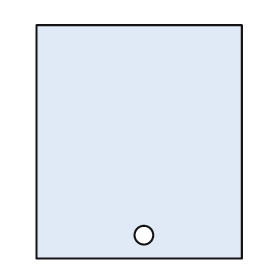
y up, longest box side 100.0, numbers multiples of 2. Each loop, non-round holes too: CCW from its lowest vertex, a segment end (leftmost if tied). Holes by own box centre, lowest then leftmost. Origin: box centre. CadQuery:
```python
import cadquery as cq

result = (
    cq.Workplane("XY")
    .moveTo(-44.0, -50.0)
    .lineTo(44.0, -50.0)
    .lineTo(44.0, 50.0)
    .lineTo(-44.0, 50.0)
    .close()
    .moveTo(2.0, -40.0)
    .circle(4.0)
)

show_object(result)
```